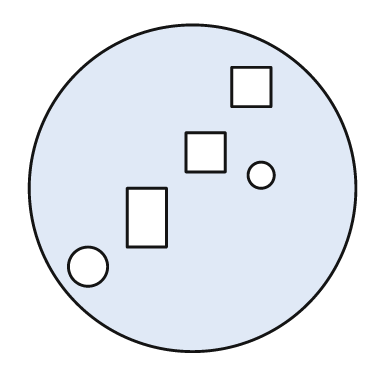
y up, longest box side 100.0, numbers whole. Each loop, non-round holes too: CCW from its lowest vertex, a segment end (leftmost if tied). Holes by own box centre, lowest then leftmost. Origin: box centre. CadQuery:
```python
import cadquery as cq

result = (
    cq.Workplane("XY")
    .moveTo(0.0, 0.0)
    .circle(50.0)
    .moveTo(-32.0, -24.0)
    .circle(6.0)
    .moveTo(-20.0, -18.0)
    .lineTo(-8.0, -18.0)
    .lineTo(-8.0, 0.0)
    .lineTo(-20.0, 0.0)
    .close()
    .moveTo(21.0, 4.0)
    .circle(4.0)
    .moveTo(-2.0, 5.0)
    .lineTo(10.0, 5.0)
    .lineTo(10.0, 17.0)
    .lineTo(-2.0, 17.0)
    .close()
    .moveTo(12.0, 25.0)
    .lineTo(24.0, 25.0)
    .lineTo(24.0, 37.0)
    .lineTo(12.0, 37.0)
    .close()
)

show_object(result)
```